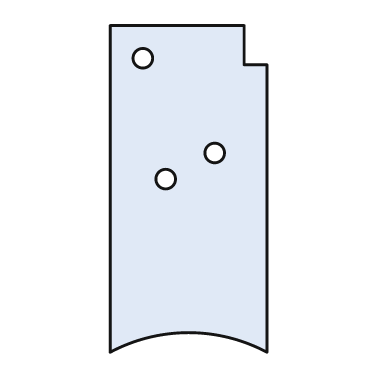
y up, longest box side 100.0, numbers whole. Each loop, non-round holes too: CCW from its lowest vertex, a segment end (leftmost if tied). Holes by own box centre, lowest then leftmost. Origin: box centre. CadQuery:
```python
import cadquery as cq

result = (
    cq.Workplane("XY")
    .moveTo(-24.0, -50.0)
    .threePointArc((0.0, -44.0), (24.0, -50.0))
    .lineTo(24.0, 38.0)
    .lineTo(17.0, 38.0)
    .lineTo(17.0, 50.0)
    .lineTo(-24.0, 50.0)
    .close()
    .moveTo(-7.0, 3.0)
    .circle(3.0)
    .moveTo(8.0, 11.0)
    .circle(3.0)
    .moveTo(-14.0, 40.0)
    .circle(3.0)
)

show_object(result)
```